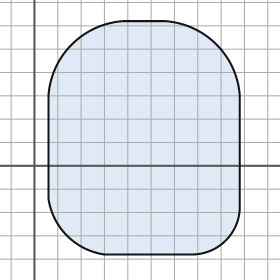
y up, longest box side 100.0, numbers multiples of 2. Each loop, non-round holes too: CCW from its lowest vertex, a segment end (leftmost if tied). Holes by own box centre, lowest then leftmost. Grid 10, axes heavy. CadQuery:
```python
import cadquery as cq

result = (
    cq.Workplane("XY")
    .moveTo(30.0, -38.0)
    .lineTo(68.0, -38.0)
    .threePointArc((82.0, -32.0), (88.0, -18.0))
    .lineTo(88.0, 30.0)
    .threePointArc((78.0, 52.0), (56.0, 62.0))
    .lineTo(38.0, 62.0)
    .threePointArc((16.0, 52.0), (6.0, 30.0))
    .lineTo(6.0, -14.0)
    .threePointArc((14.0, -30.0), (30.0, -38.0))
    .close()
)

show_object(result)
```